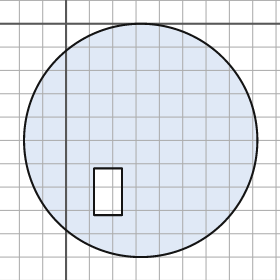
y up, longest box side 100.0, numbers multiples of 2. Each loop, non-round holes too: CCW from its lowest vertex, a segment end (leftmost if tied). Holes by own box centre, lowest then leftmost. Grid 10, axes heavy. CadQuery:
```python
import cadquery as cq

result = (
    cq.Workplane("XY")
    .moveTo(32.0, -50.0)
    .circle(50.0)
    .moveTo(12.0, -82.0)
    .lineTo(24.0, -82.0)
    .lineTo(24.0, -62.0)
    .lineTo(12.0, -62.0)
    .close()
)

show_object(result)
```